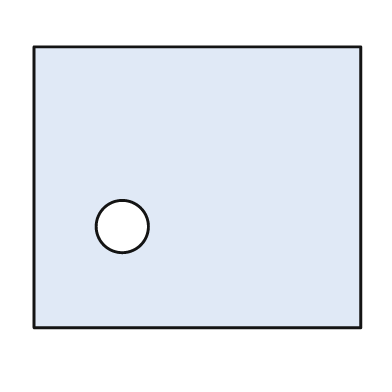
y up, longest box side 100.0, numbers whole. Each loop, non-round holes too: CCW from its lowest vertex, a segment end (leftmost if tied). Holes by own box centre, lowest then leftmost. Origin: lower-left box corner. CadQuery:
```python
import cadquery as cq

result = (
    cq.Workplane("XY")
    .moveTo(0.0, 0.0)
    .lineTo(100.0, 0.0)
    .lineTo(100.0, 86.0)
    .lineTo(0.0, 86.0)
    .close()
    .moveTo(27.0, 31.0)
    .circle(8.0)
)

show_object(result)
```